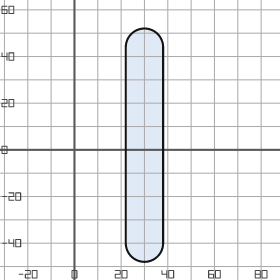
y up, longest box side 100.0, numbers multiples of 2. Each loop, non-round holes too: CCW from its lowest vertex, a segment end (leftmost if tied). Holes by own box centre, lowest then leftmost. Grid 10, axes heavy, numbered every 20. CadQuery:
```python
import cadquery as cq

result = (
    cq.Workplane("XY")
    .moveTo(22.0, -40.0)
    .threePointArc((30.0, -48.0), (38.0, -40.0))
    .lineTo(38.0, 44.0)
    .threePointArc((30.0, 52.0), (22.0, 44.0))
    .close()
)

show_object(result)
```